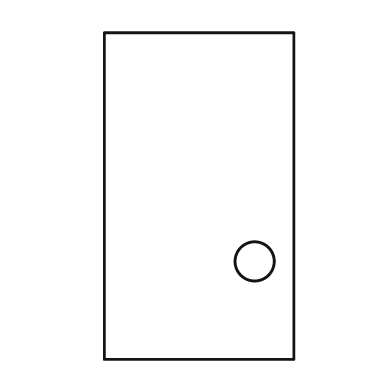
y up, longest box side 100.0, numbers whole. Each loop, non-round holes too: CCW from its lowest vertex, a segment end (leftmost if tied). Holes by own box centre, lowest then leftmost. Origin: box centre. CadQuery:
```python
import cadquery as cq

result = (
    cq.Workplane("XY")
    .moveTo(-29.0, -50.0)
    .lineTo(29.0, -50.0)
    .lineTo(29.0, 50.0)
    .lineTo(-29.0, 50.0)
    .close()
    .moveTo(17.0, -20.0)
    .circle(6.0)
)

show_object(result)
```